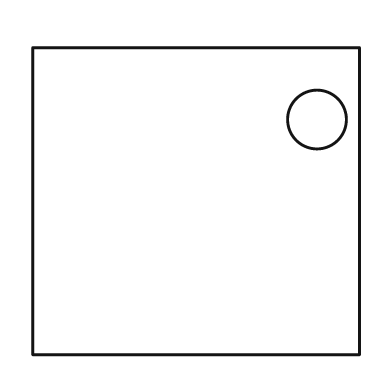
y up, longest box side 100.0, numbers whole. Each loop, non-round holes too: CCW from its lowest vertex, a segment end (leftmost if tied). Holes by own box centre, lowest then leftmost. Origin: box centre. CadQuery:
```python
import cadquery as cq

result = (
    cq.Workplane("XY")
    .moveTo(-50.0, -47.0)
    .lineTo(50.0, -47.0)
    .lineTo(50.0, 47.0)
    .lineTo(-50.0, 47.0)
    .close()
    .moveTo(37.0, 25.0)
    .circle(9.0)
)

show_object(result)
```